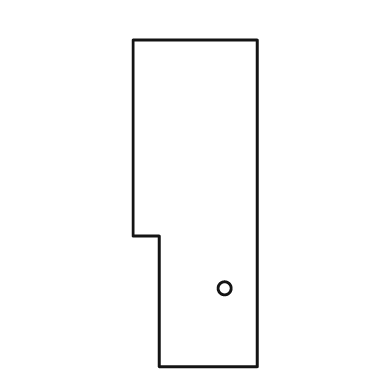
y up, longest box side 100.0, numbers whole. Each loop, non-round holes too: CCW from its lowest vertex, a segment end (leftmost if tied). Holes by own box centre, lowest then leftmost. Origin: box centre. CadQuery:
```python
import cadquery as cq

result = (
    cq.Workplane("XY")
    .moveTo(-11.0, -50.0)
    .lineTo(19.0, -50.0)
    .lineTo(19.0, 50.0)
    .lineTo(-19.0, 50.0)
    .lineTo(-19.0, -10.0)
    .lineTo(-11.0, -10.0)
    .close()
    .moveTo(9.0, -26.0)
    .circle(2.0)
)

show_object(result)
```